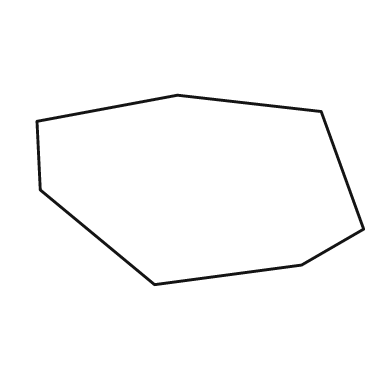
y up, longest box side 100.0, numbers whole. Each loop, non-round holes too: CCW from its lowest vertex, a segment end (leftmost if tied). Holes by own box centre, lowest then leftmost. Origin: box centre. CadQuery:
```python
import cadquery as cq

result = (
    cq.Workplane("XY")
    .moveTo(-14.0, -29.0)
    .lineTo(31.0, -23.0)
    .lineTo(50.0, -12.0)
    .lineTo(37.0, 24.0)
    .lineTo(-7.0, 29.0)
    .lineTo(-50.0, 21.0)
    .lineTo(-49.0, 0.0)
    .close()
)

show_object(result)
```